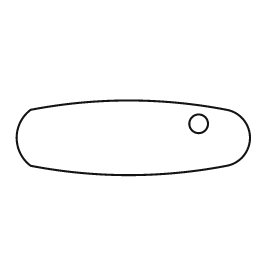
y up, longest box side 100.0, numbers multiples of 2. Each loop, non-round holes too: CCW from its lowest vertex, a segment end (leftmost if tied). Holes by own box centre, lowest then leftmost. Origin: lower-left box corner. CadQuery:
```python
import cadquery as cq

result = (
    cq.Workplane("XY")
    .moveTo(6.0, 4.0)
    .threePointArc((48.0, 0.0), (90.0, 4.0))
    .threePointArc((100.0, 16.0), (90.0, 28.0))
    .threePointArc((48.0, 32.0), (6.0, 28.0))
    .threePointArc((0.0, 16.0), (6.0, 4.0))
    .close()
    .moveTo(78.0, 22.0)
    .circle(4.0)
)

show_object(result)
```